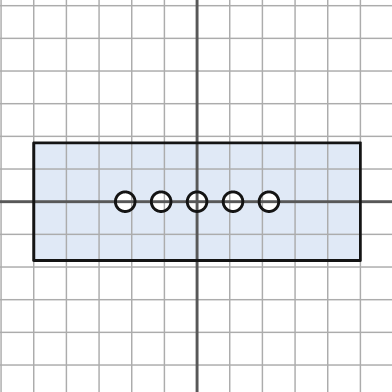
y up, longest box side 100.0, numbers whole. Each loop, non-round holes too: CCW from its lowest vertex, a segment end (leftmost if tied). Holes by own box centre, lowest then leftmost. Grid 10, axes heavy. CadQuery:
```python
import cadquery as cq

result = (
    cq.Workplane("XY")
    .moveTo(-50.0, -18.0)
    .lineTo(50.0, -18.0)
    .lineTo(50.0, 18.0)
    .lineTo(-50.0, 18.0)
    .close()
    .moveTo(-22.0, 0.0)
    .circle(3.0)
    .moveTo(-11.0, 0.0)
    .circle(3.0)
    .moveTo(0.0, 0.0)
    .circle(3.0)
    .moveTo(11.0, 0.0)
    .circle(3.0)
    .moveTo(22.0, 0.0)
    .circle(3.0)
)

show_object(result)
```